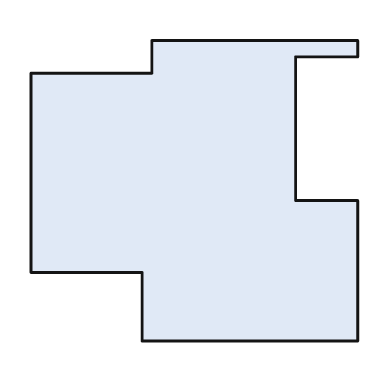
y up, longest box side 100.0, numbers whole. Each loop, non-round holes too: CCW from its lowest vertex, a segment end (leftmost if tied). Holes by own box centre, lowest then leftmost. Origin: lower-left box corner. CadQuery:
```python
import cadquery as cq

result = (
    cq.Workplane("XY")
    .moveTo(34.0, 0.0)
    .lineTo(100.0, 0.0)
    .lineTo(100.0, 43.0)
    .lineTo(81.0, 43.0)
    .lineTo(81.0, 87.0)
    .lineTo(100.0, 87.0)
    .lineTo(100.0, 92.0)
    .lineTo(37.0, 92.0)
    .lineTo(37.0, 82.0)
    .lineTo(0.0, 82.0)
    .lineTo(0.0, 21.0)
    .lineTo(34.0, 21.0)
    .close()
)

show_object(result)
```